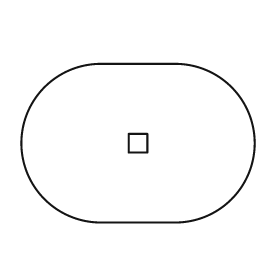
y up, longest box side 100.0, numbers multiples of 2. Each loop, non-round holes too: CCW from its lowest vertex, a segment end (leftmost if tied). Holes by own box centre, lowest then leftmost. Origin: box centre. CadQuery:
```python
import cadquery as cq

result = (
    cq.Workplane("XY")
    .moveTo(-16.0, -34.0)
    .lineTo(16.0, -34.0)
    .threePointArc((50.0, 0.0), (16.0, 34.0))
    .lineTo(-16.0, 34.0)
    .threePointArc((-50.0, 0.0), (-16.0, -34.0))
    .close()
    .moveTo(-4.0, -4.0)
    .lineTo(4.0, -4.0)
    .lineTo(4.0, 4.0)
    .lineTo(-4.0, 4.0)
    .close()
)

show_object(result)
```